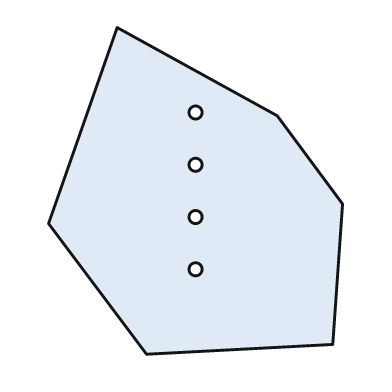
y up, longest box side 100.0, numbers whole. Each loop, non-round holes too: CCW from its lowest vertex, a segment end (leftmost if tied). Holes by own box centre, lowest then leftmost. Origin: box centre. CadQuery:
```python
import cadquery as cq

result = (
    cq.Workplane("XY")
    .moveTo(-15.0, -50.0)
    .lineTo(42.0, -47.0)
    .lineTo(45.0, -4.0)
    .lineTo(25.0, 23.0)
    .lineTo(-24.0, 50.0)
    .lineTo(-45.0, -10.0)
    .close()
    .moveTo(0.0, -24.0)
    .circle(2.0)
    .moveTo(0.0, -8.0)
    .circle(2.0)
    .moveTo(0.0, 8.0)
    .circle(2.0)
    .moveTo(0.0, 24.0)
    .circle(2.0)
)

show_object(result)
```